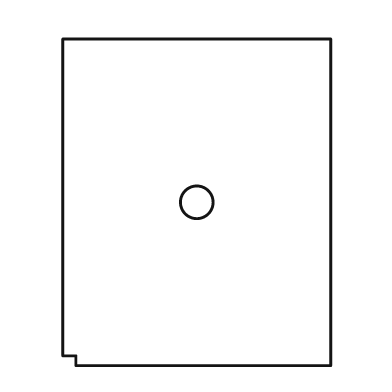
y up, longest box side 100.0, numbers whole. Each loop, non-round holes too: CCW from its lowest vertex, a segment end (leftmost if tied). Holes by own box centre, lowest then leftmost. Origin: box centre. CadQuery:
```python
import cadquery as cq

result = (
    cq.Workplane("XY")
    .moveTo(-37.0, -50.0)
    .lineTo(41.0, -50.0)
    .lineTo(41.0, 50.0)
    .lineTo(-41.0, 50.0)
    .lineTo(-41.0, -47.0)
    .lineTo(-37.0, -47.0)
    .close()
    .moveTo(0.0, 0.0)
    .circle(5.0)
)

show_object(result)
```